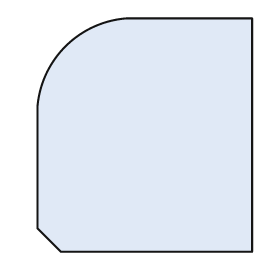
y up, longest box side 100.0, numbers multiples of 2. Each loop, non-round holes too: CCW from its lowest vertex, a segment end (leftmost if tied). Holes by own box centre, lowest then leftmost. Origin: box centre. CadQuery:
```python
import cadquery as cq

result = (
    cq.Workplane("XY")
    .moveTo(-36.0, -50.0)
    .lineTo(46.0, -50.0)
    .lineTo(46.0, 50.0)
    .lineTo(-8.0, 50.0)
    .threePointArc((-34.0, 38.0), (-46.0, 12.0))
    .lineTo(-46.0, -40.0)
    .close()
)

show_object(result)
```